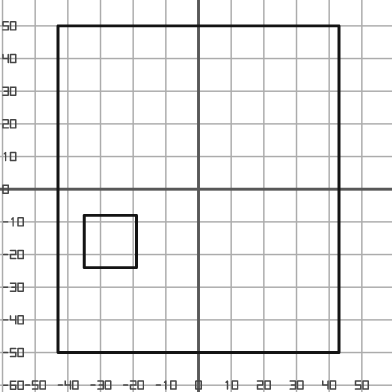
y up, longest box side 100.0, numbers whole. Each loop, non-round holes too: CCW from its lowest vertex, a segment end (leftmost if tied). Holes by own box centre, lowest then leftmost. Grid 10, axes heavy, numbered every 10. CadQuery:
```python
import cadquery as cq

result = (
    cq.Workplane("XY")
    .moveTo(-43.0, -50.0)
    .lineTo(43.0, -50.0)
    .lineTo(43.0, 50.0)
    .lineTo(-43.0, 50.0)
    .close()
    .moveTo(-35.0, -24.0)
    .lineTo(-19.0, -24.0)
    .lineTo(-19.0, -8.0)
    .lineTo(-35.0, -8.0)
    .close()
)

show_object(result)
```